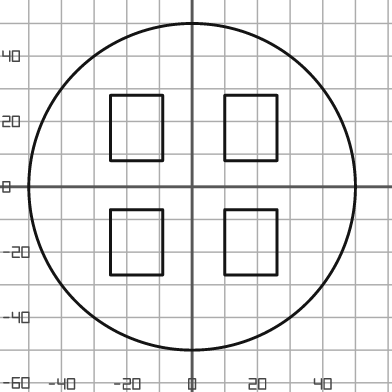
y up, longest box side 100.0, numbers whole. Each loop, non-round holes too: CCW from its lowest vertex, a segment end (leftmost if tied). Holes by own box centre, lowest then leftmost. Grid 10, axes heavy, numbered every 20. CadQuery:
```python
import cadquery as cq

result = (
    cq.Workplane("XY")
    .moveTo(0.0, 0.0)
    .circle(50.0)
    .moveTo(-25.0, -27.0)
    .lineTo(-9.0, -27.0)
    .lineTo(-9.0, -7.0)
    .lineTo(-25.0, -7.0)
    .close()
    .moveTo(10.0, -27.0)
    .lineTo(26.0, -27.0)
    .lineTo(26.0, -7.0)
    .lineTo(10.0, -7.0)
    .close()
    .moveTo(-25.0, 8.0)
    .lineTo(-9.0, 8.0)
    .lineTo(-9.0, 28.0)
    .lineTo(-25.0, 28.0)
    .close()
    .moveTo(10.0, 8.0)
    .lineTo(26.0, 8.0)
    .lineTo(26.0, 28.0)
    .lineTo(10.0, 28.0)
    .close()
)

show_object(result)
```